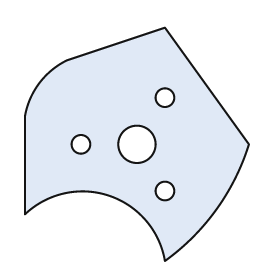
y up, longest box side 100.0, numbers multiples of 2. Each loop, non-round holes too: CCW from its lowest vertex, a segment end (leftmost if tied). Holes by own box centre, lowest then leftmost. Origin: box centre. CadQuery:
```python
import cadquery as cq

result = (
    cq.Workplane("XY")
    .moveTo(12.0, -50.0)
    .threePointArc((34.0, -28.0), (48.0, 0.0))
    .lineTo(12.0, 50.0)
    .lineTo(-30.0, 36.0)
    .threePointArc((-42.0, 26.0), (-48.0, 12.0))
    .lineTo(-48.0, -30.0)
    .threePointArc((-12.0, -22.0), (12.0, -50.0))
    .close()
    .moveTo(12.0, -20.0)
    .circle(4.0)
    .moveTo(-24.0, 0.0)
    .circle(4.0)
    .moveTo(0.0, 0.0)
    .circle(8.0)
    .moveTo(12.0, 20.0)
    .circle(4.0)
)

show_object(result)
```